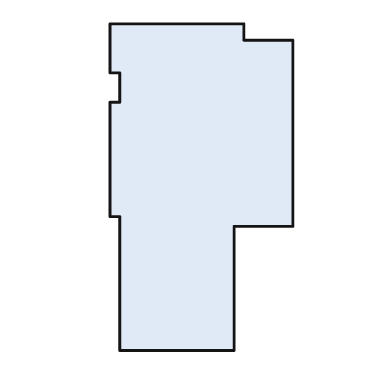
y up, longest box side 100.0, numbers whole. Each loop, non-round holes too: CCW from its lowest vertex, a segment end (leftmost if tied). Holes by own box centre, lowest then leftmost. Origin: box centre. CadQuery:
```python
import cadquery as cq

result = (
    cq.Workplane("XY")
    .moveTo(-25.0, -50.0)
    .lineTo(10.0, -50.0)
    .lineTo(10.0, -12.0)
    .lineTo(28.0, -12.0)
    .lineTo(28.0, 45.0)
    .lineTo(13.0, 45.0)
    .lineTo(13.0, 50.0)
    .lineTo(-28.0, 50.0)
    .lineTo(-28.0, 35.0)
    .lineTo(-25.0, 35.0)
    .lineTo(-25.0, 26.0)
    .lineTo(-28.0, 26.0)
    .lineTo(-28.0, -9.0)
    .lineTo(-25.0, -9.0)
    .close()
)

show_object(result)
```